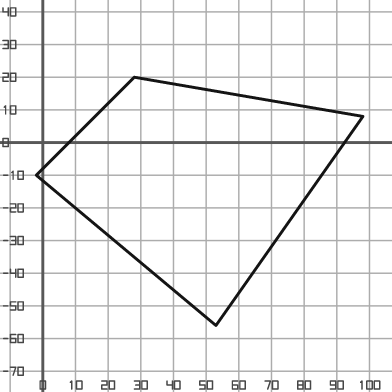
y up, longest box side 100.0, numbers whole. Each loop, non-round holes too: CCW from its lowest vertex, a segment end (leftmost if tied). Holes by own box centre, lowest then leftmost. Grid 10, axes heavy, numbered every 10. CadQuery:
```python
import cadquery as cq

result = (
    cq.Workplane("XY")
    .moveTo(53.0, -56.0)
    .lineTo(98.0, 8.0)
    .lineTo(28.0, 20.0)
    .lineTo(-2.0, -10.0)
    .close()
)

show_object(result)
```